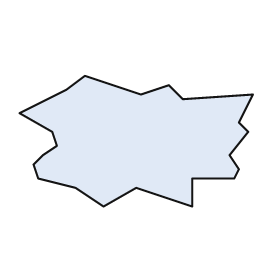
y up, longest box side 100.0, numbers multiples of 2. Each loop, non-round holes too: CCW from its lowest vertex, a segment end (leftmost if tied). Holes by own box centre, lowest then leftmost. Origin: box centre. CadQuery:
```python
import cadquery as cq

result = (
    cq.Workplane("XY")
    .moveTo(-14.0, -28.0)
    .lineTo(0.0, -20.0)
    .lineTo(24.0, -28.0)
    .lineTo(24.0, -16.0)
    .lineTo(42.0, -16.0)
    .lineTo(44.0, -12.0)
    .lineTo(40.0, -6.0)
    .lineTo(48.0, 4.0)
    .lineTo(44.0, 8.0)
    .lineTo(50.0, 20.0)
    .lineTo(20.0, 18.0)
    .lineTo(14.0, 24.0)
    .lineTo(2.0, 20.0)
    .lineTo(-22.0, 28.0)
    .lineTo(-30.0, 22.0)
    .lineTo(-50.0, 12.0)
    .lineTo(-36.0, 4.0)
    .lineTo(-34.0, -2.0)
    .lineTo(-40.0, -6.0)
    .lineTo(-44.0, -10.0)
    .lineTo(-42.0, -16.0)
    .lineTo(-26.0, -20.0)
    .close()
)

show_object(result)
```